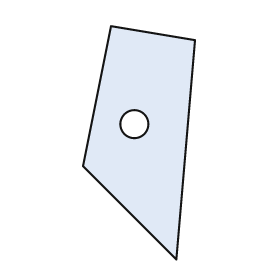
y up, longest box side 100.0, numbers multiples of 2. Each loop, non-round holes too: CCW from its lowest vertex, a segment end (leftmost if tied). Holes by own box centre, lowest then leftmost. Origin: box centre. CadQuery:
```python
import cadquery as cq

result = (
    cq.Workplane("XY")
    .moveTo(16.0, -50.0)
    .lineTo(24.0, 44.0)
    .lineTo(-12.0, 50.0)
    .lineTo(-24.0, -10.0)
    .close()
    .moveTo(-2.0, 8.0)
    .circle(6.0)
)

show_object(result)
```